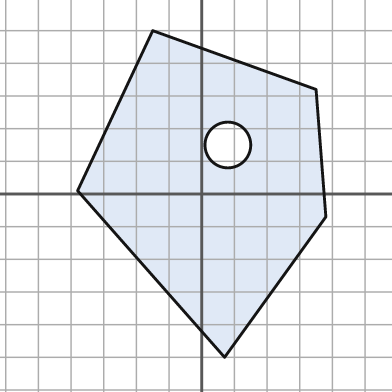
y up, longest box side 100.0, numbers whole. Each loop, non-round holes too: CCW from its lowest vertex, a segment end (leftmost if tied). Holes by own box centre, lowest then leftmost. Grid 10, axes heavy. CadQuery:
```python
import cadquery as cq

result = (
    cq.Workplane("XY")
    .moveTo(7.0, -50.0)
    .lineTo(38.0, -7.0)
    .lineTo(35.0, 32.0)
    .lineTo(-15.0, 50.0)
    .lineTo(-38.0, 1.0)
    .close()
    .moveTo(8.0, 15.0)
    .circle(7.0)
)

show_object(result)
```